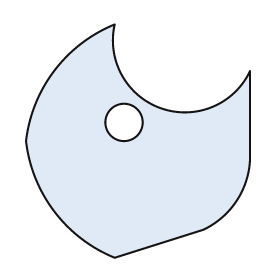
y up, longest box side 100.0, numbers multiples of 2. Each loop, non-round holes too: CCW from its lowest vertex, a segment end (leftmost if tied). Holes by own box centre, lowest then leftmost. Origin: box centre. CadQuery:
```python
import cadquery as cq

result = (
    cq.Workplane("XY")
    .moveTo(-10.0, -50.0)
    .lineTo(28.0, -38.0)
    .threePointArc((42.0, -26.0), (48.0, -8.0))
    .lineTo(48.0, 30.0)
    .threePointArc((10.0, 14.0), (-10.0, 50.0))
    .threePointArc((-36.0, 30.0), (-48.0, 0.0))
    .threePointArc((-36.0, -30.0), (-10.0, -50.0))
    .close()
    .moveTo(-6.0, 8.0)
    .circle(8.0)
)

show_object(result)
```